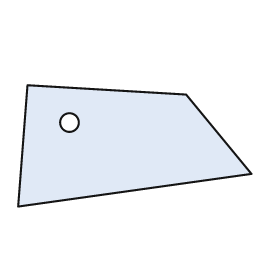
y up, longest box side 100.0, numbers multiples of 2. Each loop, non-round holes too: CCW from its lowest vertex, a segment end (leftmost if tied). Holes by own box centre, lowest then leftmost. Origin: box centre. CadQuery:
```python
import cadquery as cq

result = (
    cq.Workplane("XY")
    .moveTo(-50.0, -26.0)
    .lineTo(50.0, -12.0)
    .lineTo(22.0, 22.0)
    .lineTo(-46.0, 26.0)
    .close()
    .moveTo(-28.0, 10.0)
    .circle(4.0)
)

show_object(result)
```